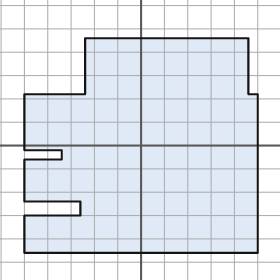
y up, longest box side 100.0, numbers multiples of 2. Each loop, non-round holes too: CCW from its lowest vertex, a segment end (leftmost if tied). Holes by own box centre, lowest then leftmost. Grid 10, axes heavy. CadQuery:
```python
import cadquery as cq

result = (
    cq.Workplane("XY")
    .moveTo(-50.0, -46.0)
    .lineTo(50.0, -46.0)
    .lineTo(50.0, 22.0)
    .lineTo(46.0, 22.0)
    .lineTo(46.0, 46.0)
    .lineTo(-24.0, 46.0)
    .lineTo(-24.0, 22.0)
    .lineTo(-50.0, 22.0)
    .lineTo(-50.0, -2.0)
    .lineTo(-34.0, -2.0)
    .lineTo(-34.0, -6.0)
    .lineTo(-50.0, -6.0)
    .lineTo(-50.0, -24.0)
    .lineTo(-26.0, -24.0)
    .lineTo(-26.0, -30.0)
    .lineTo(-50.0, -30.0)
    .close()
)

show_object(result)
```